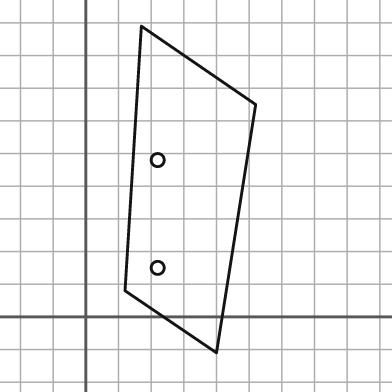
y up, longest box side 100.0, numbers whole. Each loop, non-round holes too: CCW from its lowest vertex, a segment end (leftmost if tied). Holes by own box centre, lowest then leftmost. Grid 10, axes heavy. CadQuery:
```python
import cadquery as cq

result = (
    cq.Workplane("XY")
    .moveTo(40.0, -11.0)
    .lineTo(52.0, 65.0)
    .lineTo(17.0, 89.0)
    .lineTo(12.0, 8.0)
    .close()
    .moveTo(22.0, 15.0)
    .circle(2.0)
    .moveTo(22.0, 48.0)
    .circle(2.0)
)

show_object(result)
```